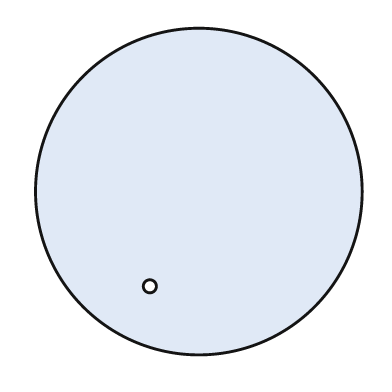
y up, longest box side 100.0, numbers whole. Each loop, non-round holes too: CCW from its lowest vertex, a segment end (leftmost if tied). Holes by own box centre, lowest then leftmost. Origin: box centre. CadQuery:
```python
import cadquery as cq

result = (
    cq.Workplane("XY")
    .moveTo(0.0, 0.0)
    .circle(50.0)
    .moveTo(-15.0, -29.0)
    .circle(2.0)
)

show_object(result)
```